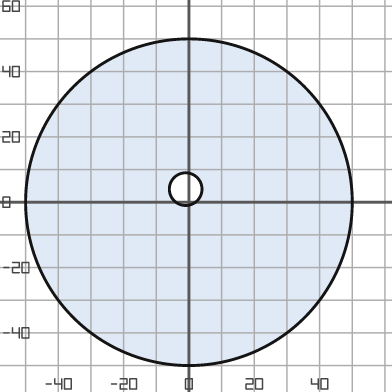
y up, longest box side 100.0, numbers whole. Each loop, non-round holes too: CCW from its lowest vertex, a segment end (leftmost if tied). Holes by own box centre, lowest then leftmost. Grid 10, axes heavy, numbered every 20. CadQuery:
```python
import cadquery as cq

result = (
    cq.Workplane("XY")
    .moveTo(0.0, 0.0)
    .circle(50.0)
    .moveTo(-1.0, 4.0)
    .circle(5.0)
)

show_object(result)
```